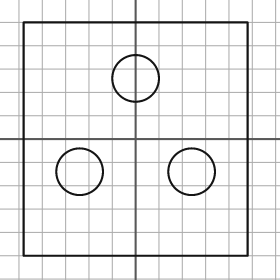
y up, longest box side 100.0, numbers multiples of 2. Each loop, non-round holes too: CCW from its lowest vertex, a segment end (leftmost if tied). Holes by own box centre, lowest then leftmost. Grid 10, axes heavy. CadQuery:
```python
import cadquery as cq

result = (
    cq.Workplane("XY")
    .moveTo(-48.0, -50.0)
    .lineTo(48.0, -50.0)
    .lineTo(48.0, 50.0)
    .lineTo(-48.0, 50.0)
    .close()
    .moveTo(-24.0, -14.0)
    .circle(10.0)
    .moveTo(24.0, -14.0)
    .circle(10.0)
    .moveTo(0.0, 26.0)
    .circle(10.0)
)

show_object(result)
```